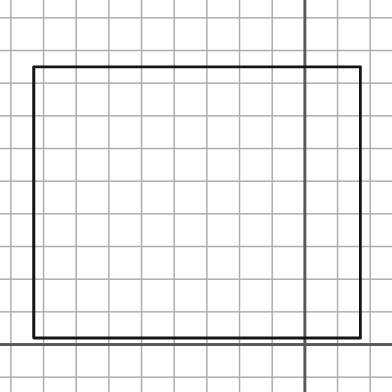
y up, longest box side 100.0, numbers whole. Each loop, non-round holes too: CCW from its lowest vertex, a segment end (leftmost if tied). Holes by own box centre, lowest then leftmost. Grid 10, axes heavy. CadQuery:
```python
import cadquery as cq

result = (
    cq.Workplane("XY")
    .moveTo(-83.0, 2.0)
    .lineTo(17.0, 2.0)
    .lineTo(17.0, 85.0)
    .lineTo(-83.0, 85.0)
    .close()
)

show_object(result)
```